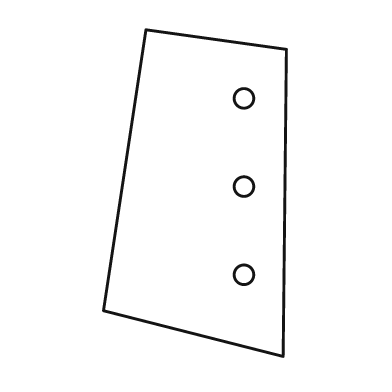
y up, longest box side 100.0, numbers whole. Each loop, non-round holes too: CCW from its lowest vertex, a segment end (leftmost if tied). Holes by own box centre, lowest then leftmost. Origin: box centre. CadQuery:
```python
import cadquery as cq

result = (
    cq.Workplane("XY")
    .moveTo(27.0, -50.0)
    .lineTo(28.0, 44.0)
    .lineTo(-15.0, 50.0)
    .lineTo(-28.0, -36.0)
    .close()
    .moveTo(15.0, -25.0)
    .circle(3.0)
    .moveTo(15.0, 2.0)
    .circle(3.0)
    .moveTo(15.0, 29.0)
    .circle(3.0)
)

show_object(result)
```